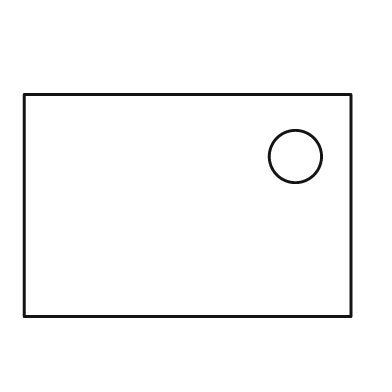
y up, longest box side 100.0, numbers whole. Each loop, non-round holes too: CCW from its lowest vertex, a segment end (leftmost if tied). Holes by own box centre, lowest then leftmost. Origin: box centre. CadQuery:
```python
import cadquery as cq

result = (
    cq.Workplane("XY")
    .moveTo(-50.0, -34.0)
    .lineTo(50.0, -34.0)
    .lineTo(50.0, 34.0)
    .lineTo(-50.0, 34.0)
    .close()
    .moveTo(33.0, 15.0)
    .circle(8.0)
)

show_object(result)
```